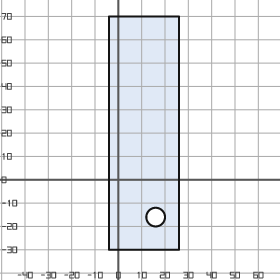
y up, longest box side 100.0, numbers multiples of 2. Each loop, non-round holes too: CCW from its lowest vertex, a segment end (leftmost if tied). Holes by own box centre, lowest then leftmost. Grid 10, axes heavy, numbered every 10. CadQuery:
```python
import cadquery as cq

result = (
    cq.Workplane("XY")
    .moveTo(-4.0, -30.0)
    .lineTo(26.0, -30.0)
    .lineTo(26.0, 70.0)
    .lineTo(-4.0, 70.0)
    .close()
    .moveTo(16.0, -16.0)
    .circle(4.0)
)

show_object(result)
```